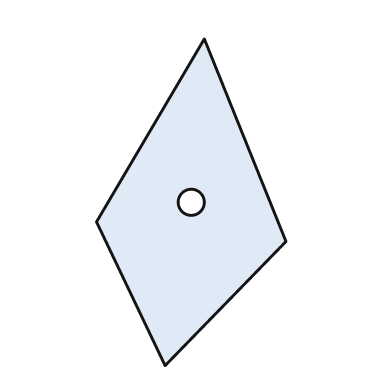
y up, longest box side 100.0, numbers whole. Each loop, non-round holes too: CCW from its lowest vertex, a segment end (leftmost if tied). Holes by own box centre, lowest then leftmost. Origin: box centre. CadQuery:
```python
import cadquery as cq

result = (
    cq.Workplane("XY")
    .moveTo(-8.0, -50.0)
    .lineTo(29.0, -12.0)
    .lineTo(4.0, 50.0)
    .lineTo(-29.0, -6.0)
    .close()
    .moveTo(0.0, 0.0)
    .circle(4.0)
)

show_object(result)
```